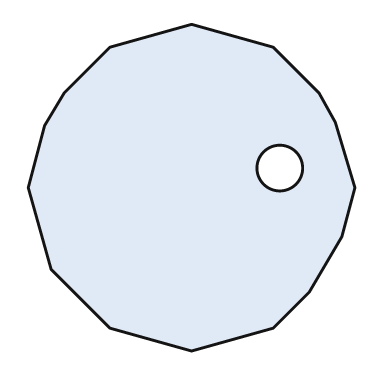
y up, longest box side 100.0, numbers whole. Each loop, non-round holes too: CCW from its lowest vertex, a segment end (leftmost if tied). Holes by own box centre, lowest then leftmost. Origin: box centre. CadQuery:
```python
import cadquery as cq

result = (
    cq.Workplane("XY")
    .moveTo(0.0, -50.0)
    .lineTo(25.0, -43.0)
    .lineTo(36.0, -32.0)
    .lineTo(46.0, -15.0)
    .lineTo(50.0, 0.0)
    .lineTo(44.0, 20.0)
    .lineTo(39.0, 29.0)
    .lineTo(25.0, 43.0)
    .lineTo(0.0, 50.0)
    .lineTo(-25.0, 43.0)
    .lineTo(-39.0, 29.0)
    .lineTo(-45.0, 19.0)
    .lineTo(-50.0, 0.0)
    .lineTo(-43.0, -25.0)
    .lineTo(-25.0, -43.0)
    .close()
    .moveTo(27.0, 6.0)
    .circle(7.0)
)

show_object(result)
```